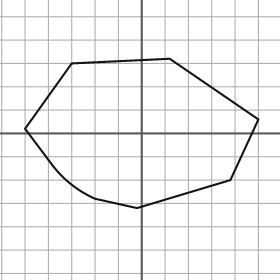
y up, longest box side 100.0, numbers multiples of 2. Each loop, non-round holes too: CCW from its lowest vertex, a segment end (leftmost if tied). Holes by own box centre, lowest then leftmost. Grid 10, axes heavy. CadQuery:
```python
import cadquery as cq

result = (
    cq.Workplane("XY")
    .moveTo(-2.0, -32.0)
    .lineTo(38.0, -20.0)
    .lineTo(50.0, 6.0)
    .lineTo(12.0, 32.0)
    .lineTo(-30.0, 30.0)
    .lineTo(-50.0, 2.0)
    .lineTo(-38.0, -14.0)
    .threePointArc((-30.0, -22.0), (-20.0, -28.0))
    .close()
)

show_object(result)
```